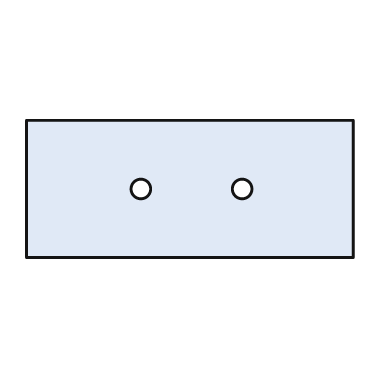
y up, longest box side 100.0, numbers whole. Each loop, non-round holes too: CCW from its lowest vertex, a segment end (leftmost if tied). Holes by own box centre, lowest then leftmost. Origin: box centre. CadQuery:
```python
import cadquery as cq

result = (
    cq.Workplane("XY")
    .moveTo(-50.0, -21.0)
    .lineTo(50.0, -21.0)
    .lineTo(50.0, 21.0)
    .lineTo(-50.0, 21.0)
    .close()
    .moveTo(-15.0, 0.0)
    .circle(3.0)
    .moveTo(16.0, 0.0)
    .circle(3.0)
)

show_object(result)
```